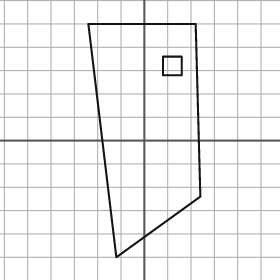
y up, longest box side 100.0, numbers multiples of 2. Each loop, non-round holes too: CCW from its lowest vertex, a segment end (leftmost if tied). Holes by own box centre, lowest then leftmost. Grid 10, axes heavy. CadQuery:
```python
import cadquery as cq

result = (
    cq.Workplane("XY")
    .moveTo(-12.0, -50.0)
    .lineTo(24.0, -24.0)
    .lineTo(22.0, 50.0)
    .lineTo(-24.0, 50.0)
    .close()
    .moveTo(8.0, 28.0)
    .lineTo(16.0, 28.0)
    .lineTo(16.0, 36.0)
    .lineTo(8.0, 36.0)
    .close()
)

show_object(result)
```